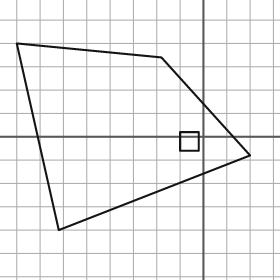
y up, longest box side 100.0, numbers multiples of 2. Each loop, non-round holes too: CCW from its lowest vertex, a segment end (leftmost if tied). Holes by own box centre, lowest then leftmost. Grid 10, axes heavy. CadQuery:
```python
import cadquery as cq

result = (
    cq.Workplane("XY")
    .moveTo(-62.0, -40.0)
    .lineTo(20.0, -8.0)
    .lineTo(-18.0, 34.0)
    .lineTo(-80.0, 40.0)
    .close()
    .moveTo(-10.0, -6.0)
    .lineTo(-2.0, -6.0)
    .lineTo(-2.0, 2.0)
    .lineTo(-10.0, 2.0)
    .close()
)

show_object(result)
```